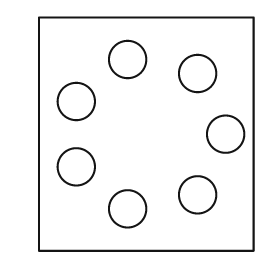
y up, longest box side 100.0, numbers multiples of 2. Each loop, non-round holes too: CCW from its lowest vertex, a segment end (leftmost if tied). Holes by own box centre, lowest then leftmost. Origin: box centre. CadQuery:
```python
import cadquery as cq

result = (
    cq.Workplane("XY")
    .moveTo(-46.0, -50.0)
    .lineTo(46.0, -50.0)
    .lineTo(46.0, 50.0)
    .lineTo(-46.0, 50.0)
    .close()
    .moveTo(-8.0, -32.0)
    .circle(8.0)
    .moveTo(22.0, -26.0)
    .circle(8.0)
    .moveTo(-30.0, -14.0)
    .circle(8.0)
    .moveTo(34.0, 0.0)
    .circle(8.0)
    .moveTo(-30.0, 14.0)
    .circle(8.0)
    .moveTo(22.0, 26.0)
    .circle(8.0)
    .moveTo(-8.0, 32.0)
    .circle(8.0)
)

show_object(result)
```